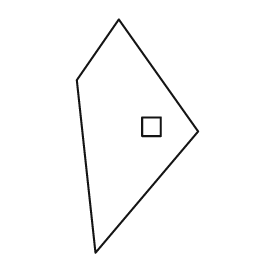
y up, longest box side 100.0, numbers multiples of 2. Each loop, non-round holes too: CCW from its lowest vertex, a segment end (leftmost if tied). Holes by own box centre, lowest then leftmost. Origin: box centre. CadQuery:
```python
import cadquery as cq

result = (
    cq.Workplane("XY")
    .moveTo(-18.0, -50.0)
    .lineTo(26.0, 2.0)
    .lineTo(-8.0, 50.0)
    .lineTo(-26.0, 24.0)
    .close()
    .moveTo(2.0, 0.0)
    .lineTo(10.0, 0.0)
    .lineTo(10.0, 8.0)
    .lineTo(2.0, 8.0)
    .close()
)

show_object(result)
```